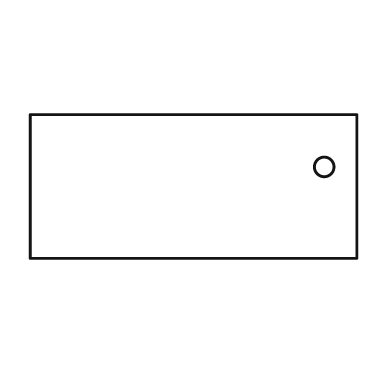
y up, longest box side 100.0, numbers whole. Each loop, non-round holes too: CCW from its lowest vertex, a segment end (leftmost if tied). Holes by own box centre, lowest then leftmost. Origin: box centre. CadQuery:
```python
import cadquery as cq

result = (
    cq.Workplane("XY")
    .moveTo(-50.0, -22.0)
    .lineTo(50.0, -22.0)
    .lineTo(50.0, 22.0)
    .lineTo(-50.0, 22.0)
    .close()
    .moveTo(40.0, 6.0)
    .circle(3.0)
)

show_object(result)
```